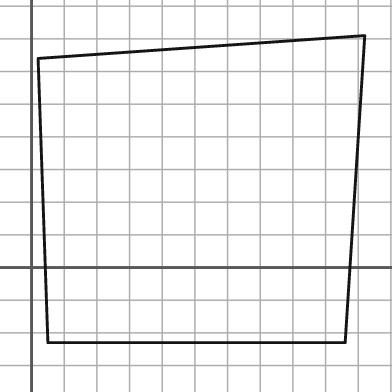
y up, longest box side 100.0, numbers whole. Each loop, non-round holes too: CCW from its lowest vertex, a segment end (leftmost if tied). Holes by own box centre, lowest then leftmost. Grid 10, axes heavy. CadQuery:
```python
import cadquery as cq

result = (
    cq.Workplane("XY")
    .moveTo(5.0, -23.0)
    .lineTo(96.0, -23.0)
    .lineTo(102.0, 71.0)
    .lineTo(2.0, 64.0)
    .close()
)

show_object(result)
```